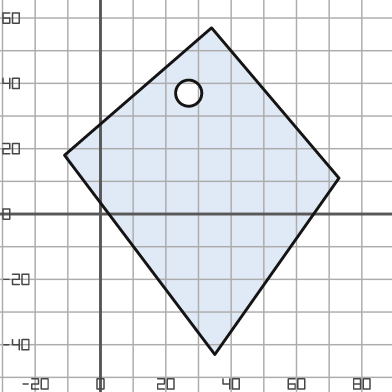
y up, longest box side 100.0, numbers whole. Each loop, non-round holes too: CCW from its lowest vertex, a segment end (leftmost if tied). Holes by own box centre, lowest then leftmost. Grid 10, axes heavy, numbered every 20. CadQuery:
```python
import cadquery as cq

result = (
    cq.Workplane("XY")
    .moveTo(35.0, -43.0)
    .lineTo(73.0, 11.0)
    .lineTo(34.0, 57.0)
    .lineTo(-11.0, 18.0)
    .close()
    .moveTo(27.0, 37.0)
    .circle(4.0)
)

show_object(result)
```